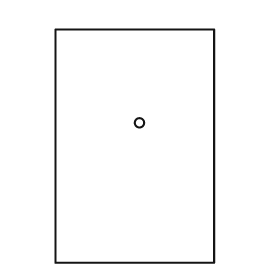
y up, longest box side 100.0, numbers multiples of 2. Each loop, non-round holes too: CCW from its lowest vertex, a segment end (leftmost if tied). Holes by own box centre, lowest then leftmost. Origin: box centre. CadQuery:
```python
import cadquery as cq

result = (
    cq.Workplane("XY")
    .moveTo(-34.0, -50.0)
    .lineTo(34.0, -50.0)
    .lineTo(34.0, 50.0)
    .lineTo(-34.0, 50.0)
    .close()
    .moveTo(2.0, 10.0)
    .circle(2.0)
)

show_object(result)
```